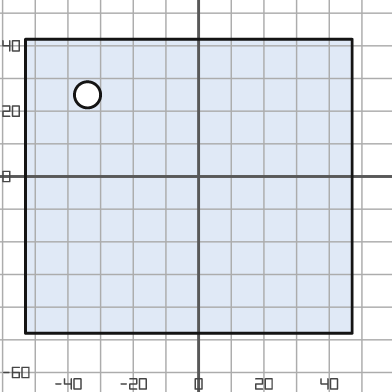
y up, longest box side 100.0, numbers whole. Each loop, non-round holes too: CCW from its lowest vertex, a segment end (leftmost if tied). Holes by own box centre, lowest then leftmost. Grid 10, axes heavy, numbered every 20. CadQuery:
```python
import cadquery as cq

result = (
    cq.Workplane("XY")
    .moveTo(-53.0, -48.0)
    .lineTo(47.0, -48.0)
    .lineTo(47.0, 42.0)
    .lineTo(-53.0, 42.0)
    .close()
    .moveTo(-34.0, 25.0)
    .circle(4.0)
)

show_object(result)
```